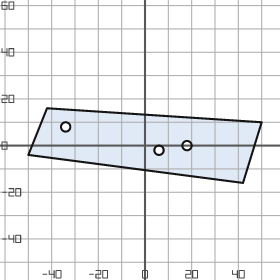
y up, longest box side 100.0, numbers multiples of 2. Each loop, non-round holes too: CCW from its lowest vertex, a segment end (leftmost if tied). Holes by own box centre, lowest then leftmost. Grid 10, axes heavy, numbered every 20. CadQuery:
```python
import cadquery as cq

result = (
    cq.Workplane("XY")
    .moveTo(42.0, -16.0)
    .lineTo(50.0, 10.0)
    .lineTo(-42.0, 16.0)
    .lineTo(-50.0, -4.0)
    .close()
    .moveTo(6.0, -2.0)
    .circle(2.0)
    .moveTo(18.0, 0.0)
    .circle(2.0)
    .moveTo(-34.0, 8.0)
    .circle(2.0)
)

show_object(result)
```